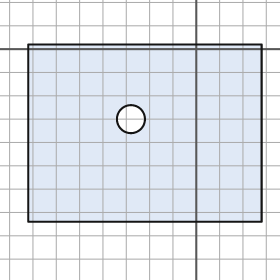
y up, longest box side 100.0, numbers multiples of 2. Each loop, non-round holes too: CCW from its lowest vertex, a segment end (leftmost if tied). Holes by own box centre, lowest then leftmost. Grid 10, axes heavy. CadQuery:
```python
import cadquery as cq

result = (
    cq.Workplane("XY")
    .moveTo(-72.0, -74.0)
    .lineTo(28.0, -74.0)
    .lineTo(28.0, 2.0)
    .lineTo(-72.0, 2.0)
    .close()
    .moveTo(-28.0, -30.0)
    .circle(6.0)
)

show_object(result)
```